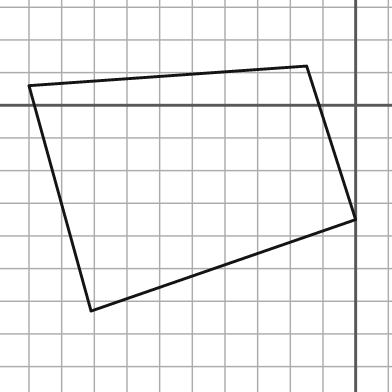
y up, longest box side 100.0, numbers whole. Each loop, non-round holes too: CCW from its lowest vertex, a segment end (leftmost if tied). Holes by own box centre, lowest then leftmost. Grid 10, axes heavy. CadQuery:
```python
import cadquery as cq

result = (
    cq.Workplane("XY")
    .moveTo(-81.0, -63.0)
    .lineTo(0.0, -35.0)
    .lineTo(-15.0, 12.0)
    .lineTo(-100.0, 6.0)
    .close()
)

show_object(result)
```